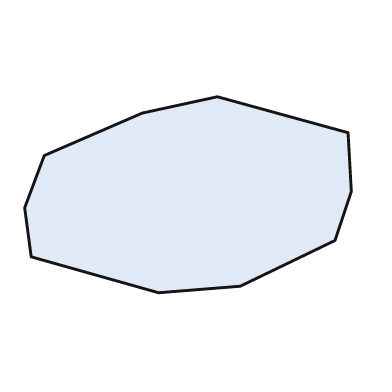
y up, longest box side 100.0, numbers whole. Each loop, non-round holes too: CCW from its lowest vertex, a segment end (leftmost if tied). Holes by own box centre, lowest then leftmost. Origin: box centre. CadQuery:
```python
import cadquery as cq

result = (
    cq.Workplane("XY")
    .moveTo(-9.0, -30.0)
    .lineTo(16.0, -28.0)
    .lineTo(45.0, -14.0)
    .lineTo(50.0, 1.0)
    .lineTo(49.0, 19.0)
    .lineTo(9.0, 30.0)
    .lineTo(-14.0, 25.0)
    .lineTo(-44.0, 12.0)
    .lineTo(-50.0, -4.0)
    .lineTo(-48.0, -19.0)
    .close()
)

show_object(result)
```